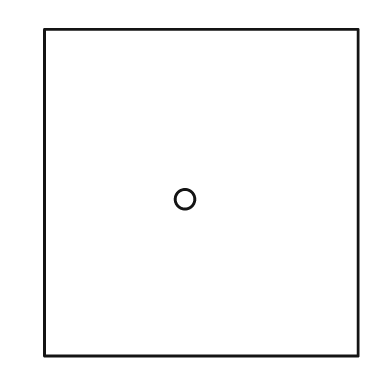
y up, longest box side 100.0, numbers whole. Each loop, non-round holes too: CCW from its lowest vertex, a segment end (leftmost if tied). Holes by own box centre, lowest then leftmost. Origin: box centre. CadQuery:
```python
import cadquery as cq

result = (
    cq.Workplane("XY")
    .moveTo(-48.0, -50.0)
    .lineTo(48.0, -50.0)
    .lineTo(48.0, 50.0)
    .lineTo(-48.0, 50.0)
    .close()
    .moveTo(-5.0, -2.0)
    .circle(3.0)
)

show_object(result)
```